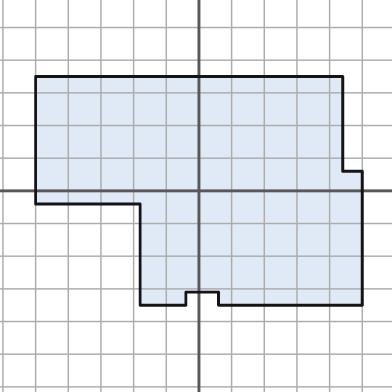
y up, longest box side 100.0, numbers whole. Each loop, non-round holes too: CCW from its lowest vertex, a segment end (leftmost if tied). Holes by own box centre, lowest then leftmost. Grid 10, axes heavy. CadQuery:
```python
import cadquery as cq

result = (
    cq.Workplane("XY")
    .moveTo(-18.0, -35.0)
    .lineTo(-4.0, -35.0)
    .lineTo(-4.0, -31.0)
    .lineTo(6.0, -31.0)
    .lineTo(6.0, -35.0)
    .lineTo(50.0, -35.0)
    .lineTo(50.0, 6.0)
    .lineTo(44.0, 6.0)
    .lineTo(44.0, 35.0)
    .lineTo(-50.0, 35.0)
    .lineTo(-50.0, -4.0)
    .lineTo(-18.0, -4.0)
    .close()
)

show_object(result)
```